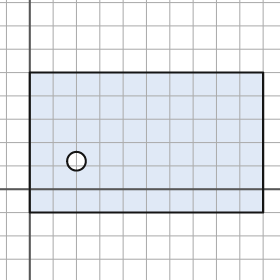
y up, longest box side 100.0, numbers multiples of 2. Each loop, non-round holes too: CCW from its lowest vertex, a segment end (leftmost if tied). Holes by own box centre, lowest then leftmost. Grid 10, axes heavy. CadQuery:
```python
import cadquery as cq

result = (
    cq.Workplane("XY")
    .moveTo(0.0, -10.0)
    .lineTo(100.0, -10.0)
    .lineTo(100.0, 50.0)
    .lineTo(0.0, 50.0)
    .close()
    .moveTo(20.0, 12.0)
    .circle(4.0)
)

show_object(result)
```